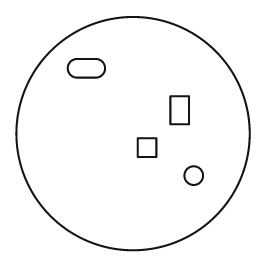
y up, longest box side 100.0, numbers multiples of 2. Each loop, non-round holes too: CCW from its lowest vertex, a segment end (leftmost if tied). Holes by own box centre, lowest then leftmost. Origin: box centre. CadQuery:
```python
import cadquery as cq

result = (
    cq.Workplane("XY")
    .moveTo(0.0, 0.0)
    .circle(50.0)
    .moveTo(26.0, -18.0)
    .circle(4.0)
    .moveTo(2.0, -10.0)
    .lineTo(10.0, -10.0)
    .lineTo(10.0, -2.0)
    .lineTo(2.0, -2.0)
    .close()
    .moveTo(16.0, 4.0)
    .lineTo(24.0, 4.0)
    .lineTo(24.0, 16.0)
    .lineTo(16.0, 16.0)
    .close()
    .moveTo(-24.0, 24.0)
    .lineTo(-16.0, 24.0)
    .threePointArc((-12.0, 28.0), (-16.0, 32.0))
    .lineTo(-24.0, 32.0)
    .threePointArc((-28.0, 28.0), (-24.0, 24.0))
    .close()
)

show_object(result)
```